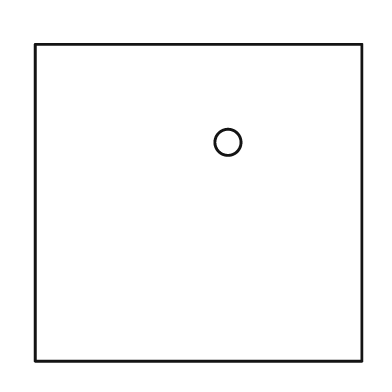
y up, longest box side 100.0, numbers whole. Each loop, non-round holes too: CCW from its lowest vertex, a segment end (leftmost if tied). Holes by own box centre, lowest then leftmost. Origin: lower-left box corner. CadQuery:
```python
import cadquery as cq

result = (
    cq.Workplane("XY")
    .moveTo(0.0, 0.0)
    .lineTo(100.0, 0.0)
    .lineTo(100.0, 97.0)
    .lineTo(0.0, 97.0)
    .close()
    .moveTo(59.0, 67.0)
    .circle(4.0)
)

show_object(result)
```